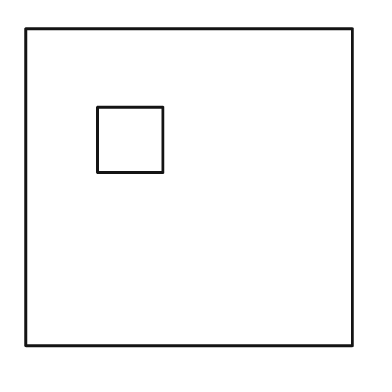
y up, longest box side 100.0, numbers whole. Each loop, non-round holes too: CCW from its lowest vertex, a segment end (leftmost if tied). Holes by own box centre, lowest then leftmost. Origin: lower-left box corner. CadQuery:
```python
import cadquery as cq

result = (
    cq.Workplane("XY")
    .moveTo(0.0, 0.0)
    .lineTo(100.0, 0.0)
    .lineTo(100.0, 97.0)
    .lineTo(0.0, 97.0)
    .close()
    .moveTo(22.0, 53.0)
    .lineTo(42.0, 53.0)
    .lineTo(42.0, 73.0)
    .lineTo(22.0, 73.0)
    .close()
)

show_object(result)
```